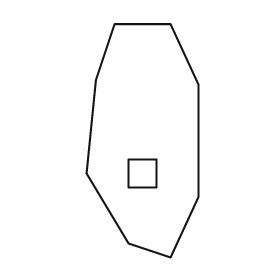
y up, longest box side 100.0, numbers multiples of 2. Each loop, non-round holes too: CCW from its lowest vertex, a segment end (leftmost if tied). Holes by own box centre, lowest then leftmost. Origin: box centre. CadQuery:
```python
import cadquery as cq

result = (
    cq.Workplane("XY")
    .moveTo(12.0, -50.0)
    .lineTo(24.0, -24.0)
    .lineTo(24.0, 24.0)
    .lineTo(12.0, 50.0)
    .lineTo(-12.0, 50.0)
    .lineTo(-20.0, 26.0)
    .lineTo(-24.0, -14.0)
    .lineTo(-6.0, -44.0)
    .close()
    .moveTo(-6.0, -20.0)
    .lineTo(6.0, -20.0)
    .lineTo(6.0, -8.0)
    .lineTo(-6.0, -8.0)
    .close()
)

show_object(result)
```